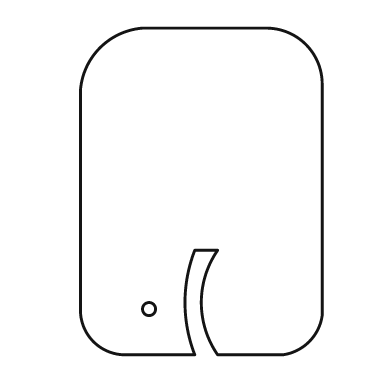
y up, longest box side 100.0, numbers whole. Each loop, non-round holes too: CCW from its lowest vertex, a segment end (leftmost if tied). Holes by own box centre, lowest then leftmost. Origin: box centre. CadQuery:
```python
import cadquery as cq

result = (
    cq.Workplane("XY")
    .moveTo(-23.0, -50.0)
    .lineTo(-2.0, -50.0)
    .threePointArc((-5.0, -34.0), (-2.0, -18.0))
    .lineTo(5.0, -18.0)
    .threePointArc((0.0, -34.0), (5.0, -50.0))
    .lineTo(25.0, -50.0)
    .threePointArc((33.0, -46.0), (37.0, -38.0))
    .lineTo(37.0, 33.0)
    .threePointArc((32.0, 45.0), (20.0, 50.0))
    .lineTo(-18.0, 50.0)
    .threePointArc((-31.0, 44.0), (-37.0, 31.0))
    .lineTo(-37.0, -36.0)
    .threePointArc((-33.0, -46.0), (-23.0, -50.0))
    .close()
    .moveTo(-16.0, -36.0)
    .circle(2.0)
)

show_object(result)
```